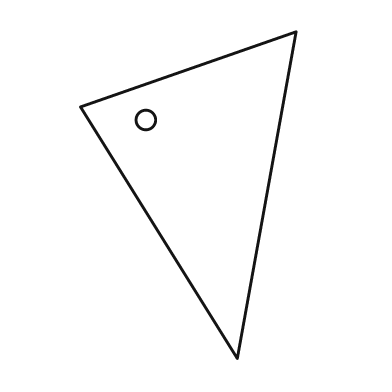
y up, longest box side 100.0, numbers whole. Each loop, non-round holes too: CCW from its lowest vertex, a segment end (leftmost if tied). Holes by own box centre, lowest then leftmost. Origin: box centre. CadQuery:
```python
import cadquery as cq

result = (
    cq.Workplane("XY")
    .moveTo(15.0, -50.0)
    .lineTo(33.0, 50.0)
    .lineTo(-33.0, 27.0)
    .close()
    .moveTo(-13.0, 23.0)
    .circle(3.0)
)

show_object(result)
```